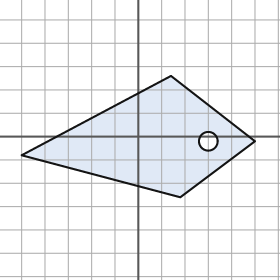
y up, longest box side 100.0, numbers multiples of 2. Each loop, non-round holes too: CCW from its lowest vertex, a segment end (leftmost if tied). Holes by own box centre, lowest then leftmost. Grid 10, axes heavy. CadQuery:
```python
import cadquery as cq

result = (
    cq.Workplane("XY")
    .moveTo(18.0, -26.0)
    .lineTo(50.0, -2.0)
    .lineTo(14.0, 26.0)
    .lineTo(-50.0, -8.0)
    .close()
    .moveTo(30.0, -2.0)
    .circle(4.0)
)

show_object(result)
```